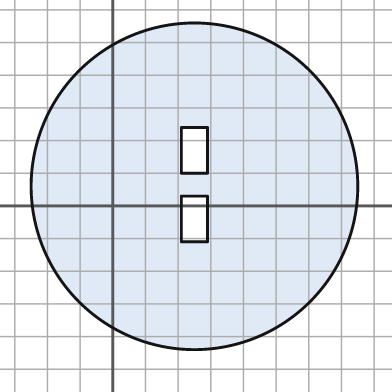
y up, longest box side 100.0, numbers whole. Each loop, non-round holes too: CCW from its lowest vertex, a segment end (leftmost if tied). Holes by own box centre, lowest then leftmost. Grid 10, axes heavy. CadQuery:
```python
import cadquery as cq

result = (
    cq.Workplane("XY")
    .moveTo(25.0, 6.0)
    .circle(50.0)
    .moveTo(21.0, -11.0)
    .lineTo(29.0, -11.0)
    .lineTo(29.0, 3.0)
    .lineTo(21.0, 3.0)
    .close()
    .moveTo(21.0, 10.0)
    .lineTo(29.0, 10.0)
    .lineTo(29.0, 24.0)
    .lineTo(21.0, 24.0)
    .close()
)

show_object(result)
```